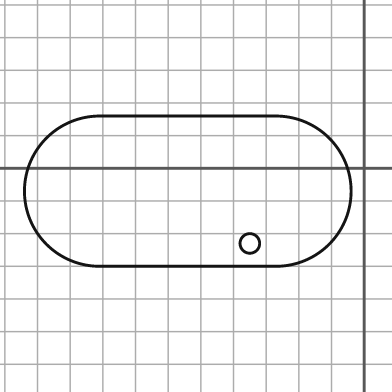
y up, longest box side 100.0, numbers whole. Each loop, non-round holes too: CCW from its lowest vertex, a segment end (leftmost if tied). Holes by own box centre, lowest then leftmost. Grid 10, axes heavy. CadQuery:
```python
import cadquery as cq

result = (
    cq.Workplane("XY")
    .moveTo(-81.0, -30.0)
    .lineTo(-27.0, -30.0)
    .threePointArc((-4.0, -7.0), (-27.0, 16.0))
    .lineTo(-81.0, 16.0)
    .threePointArc((-104.0, -7.0), (-81.0, -30.0))
    .close()
    .moveTo(-35.0, -23.0)
    .circle(3.0)
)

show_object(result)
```